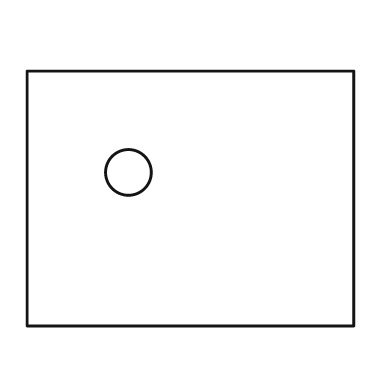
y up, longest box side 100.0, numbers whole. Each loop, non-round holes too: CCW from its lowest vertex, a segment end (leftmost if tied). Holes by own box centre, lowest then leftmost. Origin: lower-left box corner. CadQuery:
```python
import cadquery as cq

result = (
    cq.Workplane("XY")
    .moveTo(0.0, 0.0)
    .lineTo(100.0, 0.0)
    .lineTo(100.0, 78.0)
    .lineTo(0.0, 78.0)
    .close()
    .moveTo(31.0, 47.0)
    .circle(7.0)
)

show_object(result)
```